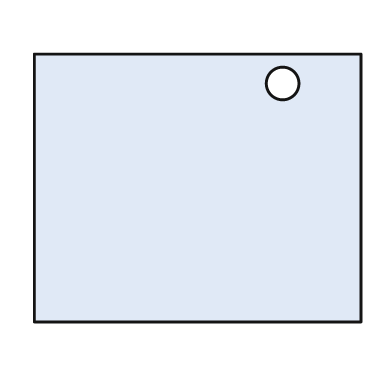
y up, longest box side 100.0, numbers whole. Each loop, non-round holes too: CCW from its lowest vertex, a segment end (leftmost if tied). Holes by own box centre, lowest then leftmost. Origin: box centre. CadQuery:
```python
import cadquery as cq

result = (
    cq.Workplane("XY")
    .moveTo(-50.0, -41.0)
    .lineTo(50.0, -41.0)
    .lineTo(50.0, 41.0)
    .lineTo(-50.0, 41.0)
    .close()
    .moveTo(26.0, 32.0)
    .circle(5.0)
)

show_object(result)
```